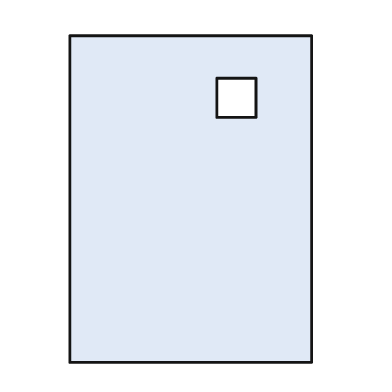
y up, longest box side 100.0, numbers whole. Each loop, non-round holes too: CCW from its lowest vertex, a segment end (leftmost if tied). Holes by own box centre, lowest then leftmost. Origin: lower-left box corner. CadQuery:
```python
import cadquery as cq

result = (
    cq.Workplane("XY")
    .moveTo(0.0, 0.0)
    .lineTo(74.0, 0.0)
    .lineTo(74.0, 100.0)
    .lineTo(0.0, 100.0)
    .close()
    .moveTo(45.0, 75.0)
    .lineTo(57.0, 75.0)
    .lineTo(57.0, 87.0)
    .lineTo(45.0, 87.0)
    .close()
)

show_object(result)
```